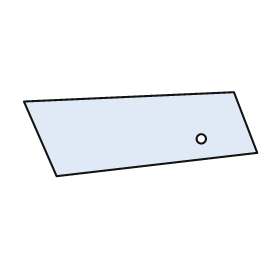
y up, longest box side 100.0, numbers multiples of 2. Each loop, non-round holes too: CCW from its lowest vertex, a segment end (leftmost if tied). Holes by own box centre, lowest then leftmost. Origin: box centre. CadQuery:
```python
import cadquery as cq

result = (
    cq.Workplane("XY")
    .moveTo(-36.0, -18.0)
    .lineTo(50.0, -8.0)
    .lineTo(40.0, 18.0)
    .lineTo(-50.0, 14.0)
    .close()
    .moveTo(26.0, -2.0)
    .circle(2.0)
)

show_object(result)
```